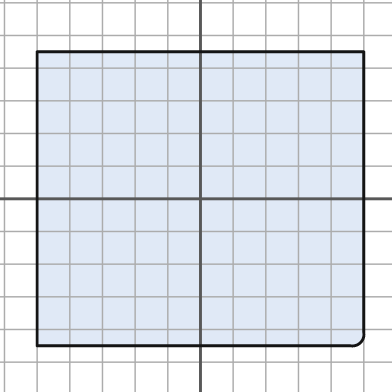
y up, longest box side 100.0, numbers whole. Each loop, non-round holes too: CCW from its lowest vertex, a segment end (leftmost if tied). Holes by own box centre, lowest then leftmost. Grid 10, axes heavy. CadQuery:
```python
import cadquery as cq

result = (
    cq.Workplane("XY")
    .moveTo(-50.0, -45.0)
    .lineTo(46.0, -45.0)
    .threePointArc((49.0, -44.0), (50.0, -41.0))
    .lineTo(50.0, 45.0)
    .lineTo(-50.0, 45.0)
    .close()
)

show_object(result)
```